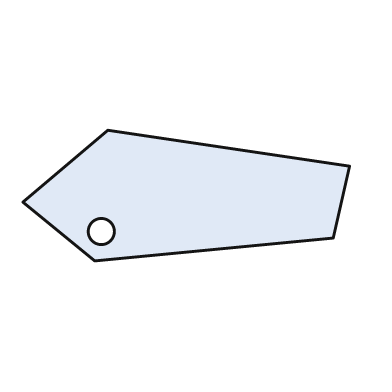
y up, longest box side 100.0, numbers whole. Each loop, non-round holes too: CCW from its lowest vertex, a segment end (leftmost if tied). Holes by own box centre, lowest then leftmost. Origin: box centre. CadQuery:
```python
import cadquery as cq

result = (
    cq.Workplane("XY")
    .moveTo(-28.0, -20.0)
    .lineTo(45.0, -13.0)
    .lineTo(50.0, 9.0)
    .lineTo(-24.0, 20.0)
    .lineTo(-50.0, -2.0)
    .close()
    .moveTo(-26.0, -11.0)
    .circle(4.0)
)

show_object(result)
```